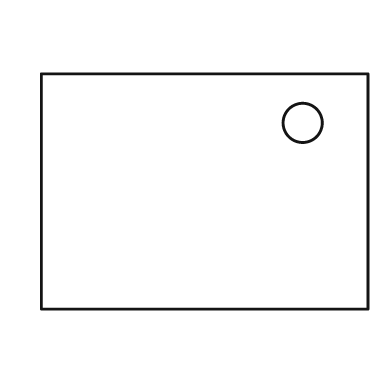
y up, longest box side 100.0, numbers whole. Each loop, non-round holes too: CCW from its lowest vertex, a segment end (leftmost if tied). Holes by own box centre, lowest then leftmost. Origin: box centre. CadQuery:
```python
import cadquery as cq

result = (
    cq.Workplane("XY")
    .moveTo(-50.0, -36.0)
    .lineTo(50.0, -36.0)
    .lineTo(50.0, 36.0)
    .lineTo(-50.0, 36.0)
    .close()
    .moveTo(30.0, 21.0)
    .circle(6.0)
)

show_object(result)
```